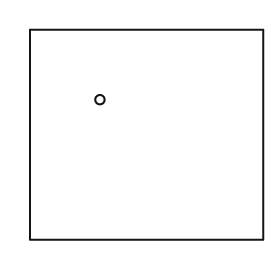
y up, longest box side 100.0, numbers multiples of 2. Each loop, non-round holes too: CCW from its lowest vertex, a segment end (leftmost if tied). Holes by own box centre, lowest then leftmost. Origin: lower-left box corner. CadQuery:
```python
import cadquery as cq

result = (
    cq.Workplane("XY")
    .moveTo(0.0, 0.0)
    .lineTo(100.0, 0.0)
    .lineTo(100.0, 90.0)
    .lineTo(0.0, 90.0)
    .close()
    .moveTo(30.0, 60.0)
    .circle(2.0)
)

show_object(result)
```